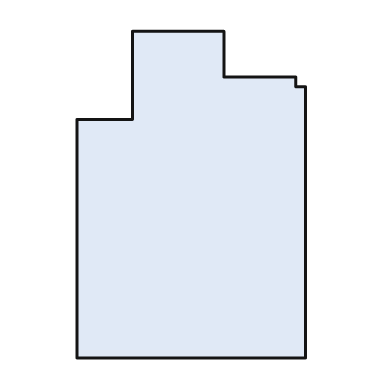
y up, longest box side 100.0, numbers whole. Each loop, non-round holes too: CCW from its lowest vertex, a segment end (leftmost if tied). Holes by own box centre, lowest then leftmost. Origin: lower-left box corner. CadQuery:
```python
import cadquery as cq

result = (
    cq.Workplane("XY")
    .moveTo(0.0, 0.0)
    .lineTo(70.0, 0.0)
    .lineTo(70.0, 83.0)
    .lineTo(67.0, 83.0)
    .lineTo(67.0, 86.0)
    .lineTo(45.0, 86.0)
    .lineTo(45.0, 100.0)
    .lineTo(17.0, 100.0)
    .lineTo(17.0, 73.0)
    .lineTo(0.0, 73.0)
    .close()
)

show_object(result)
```